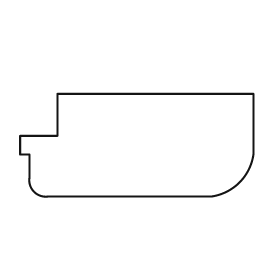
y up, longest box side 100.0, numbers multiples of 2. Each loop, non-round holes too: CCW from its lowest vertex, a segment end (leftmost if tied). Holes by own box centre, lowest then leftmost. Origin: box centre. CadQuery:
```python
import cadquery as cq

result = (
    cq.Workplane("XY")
    .moveTo(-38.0, -22.0)
    .lineTo(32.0, -22.0)
    .threePointArc((44.0, -16.0), (50.0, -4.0))
    .lineTo(50.0, 22.0)
    .lineTo(-34.0, 22.0)
    .lineTo(-34.0, 4.0)
    .lineTo(-50.0, 4.0)
    .lineTo(-50.0, -4.0)
    .lineTo(-46.0, -4.0)
    .lineTo(-46.0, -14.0)
    .threePointArc((-44.0, -20.0), (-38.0, -22.0))
    .close()
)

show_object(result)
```